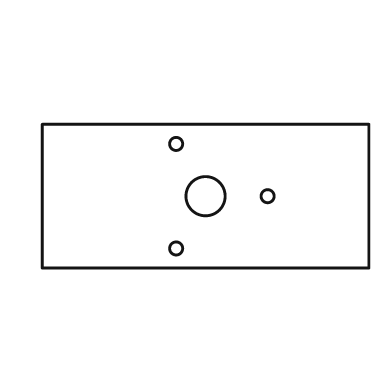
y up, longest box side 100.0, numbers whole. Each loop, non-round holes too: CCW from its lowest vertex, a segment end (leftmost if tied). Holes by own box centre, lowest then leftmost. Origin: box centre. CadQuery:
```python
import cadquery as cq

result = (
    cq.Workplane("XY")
    .moveTo(-50.0, -22.0)
    .lineTo(50.0, -22.0)
    .lineTo(50.0, 22.0)
    .lineTo(-50.0, 22.0)
    .close()
    .moveTo(-9.0, -16.0)
    .circle(2.0)
    .moveTo(0.0, 0.0)
    .circle(6.0)
    .moveTo(19.0, 0.0)
    .circle(2.0)
    .moveTo(-9.0, 16.0)
    .circle(2.0)
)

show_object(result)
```